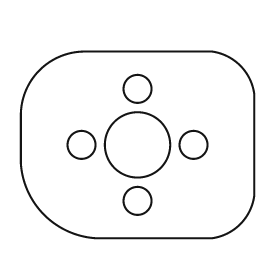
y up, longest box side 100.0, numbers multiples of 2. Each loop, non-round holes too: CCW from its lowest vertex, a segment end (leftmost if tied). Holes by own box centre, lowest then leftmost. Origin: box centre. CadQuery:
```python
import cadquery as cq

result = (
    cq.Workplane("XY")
    .moveTo(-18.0, -40.0)
    .lineTo(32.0, -40.0)
    .threePointArc((44.0, -34.0), (50.0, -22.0))
    .lineTo(50.0, 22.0)
    .threePointArc((44.0, 34.0), (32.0, 40.0))
    .lineTo(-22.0, 40.0)
    .threePointArc((-42.0, 32.0), (-50.0, 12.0))
    .lineTo(-50.0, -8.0)
    .threePointArc((-40.0, -30.0), (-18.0, -40.0))
    .close()
    .moveTo(0.0, -24.0)
    .circle(6.0)
    .moveTo(-24.0, 0.0)
    .circle(6.0)
    .moveTo(0.0, 0.0)
    .circle(14.0)
    .moveTo(24.0, 0.0)
    .circle(6.0)
    .moveTo(0.0, 24.0)
    .circle(6.0)
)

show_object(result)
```